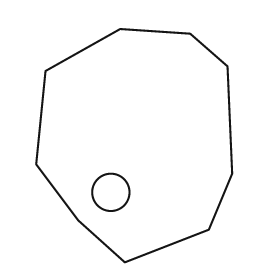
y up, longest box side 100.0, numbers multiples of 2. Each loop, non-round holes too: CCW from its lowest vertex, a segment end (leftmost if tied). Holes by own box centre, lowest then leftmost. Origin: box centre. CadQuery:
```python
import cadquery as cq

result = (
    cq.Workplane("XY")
    .moveTo(-4.0, -50.0)
    .lineTo(32.0, -36.0)
    .lineTo(42.0, -12.0)
    .lineTo(40.0, 34.0)
    .lineTo(24.0, 48.0)
    .lineTo(-6.0, 50.0)
    .lineTo(-38.0, 32.0)
    .lineTo(-42.0, -8.0)
    .lineTo(-24.0, -32.0)
    .close()
    .moveTo(-10.0, -20.0)
    .circle(8.0)
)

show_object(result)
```